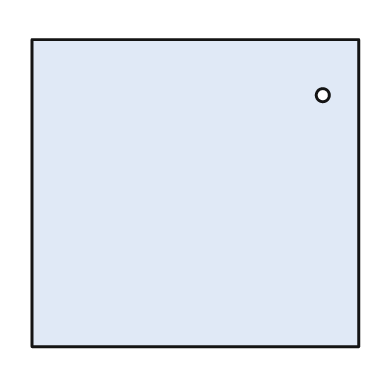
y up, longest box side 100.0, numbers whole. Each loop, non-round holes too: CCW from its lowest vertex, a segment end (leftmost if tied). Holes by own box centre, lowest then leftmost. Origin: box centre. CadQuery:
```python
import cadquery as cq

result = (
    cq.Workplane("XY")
    .moveTo(-50.0, -47.0)
    .lineTo(50.0, -47.0)
    .lineTo(50.0, 47.0)
    .lineTo(-50.0, 47.0)
    .close()
    .moveTo(39.0, 30.0)
    .circle(2.0)
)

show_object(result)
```